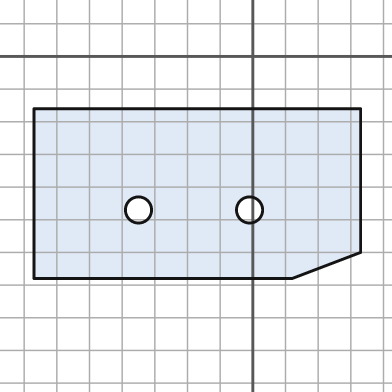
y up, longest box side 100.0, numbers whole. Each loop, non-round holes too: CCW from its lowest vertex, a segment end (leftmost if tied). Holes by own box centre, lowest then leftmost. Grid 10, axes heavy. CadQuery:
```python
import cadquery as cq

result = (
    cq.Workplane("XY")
    .moveTo(-67.0, -68.0)
    .lineTo(12.0, -68.0)
    .lineTo(33.0, -60.0)
    .lineTo(33.0, -16.0)
    .lineTo(-67.0, -16.0)
    .close()
    .moveTo(-35.0, -47.0)
    .circle(4.0)
    .moveTo(-1.0, -47.0)
    .circle(4.0)
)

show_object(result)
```